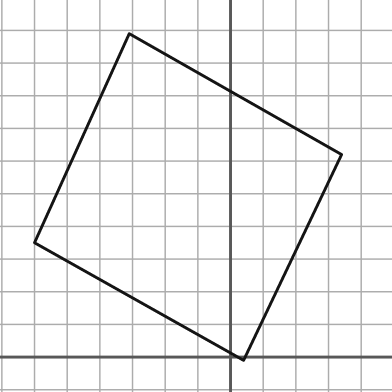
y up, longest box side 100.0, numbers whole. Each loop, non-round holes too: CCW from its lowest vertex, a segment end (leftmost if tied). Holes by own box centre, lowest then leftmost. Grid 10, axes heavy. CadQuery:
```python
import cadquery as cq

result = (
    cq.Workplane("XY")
    .moveTo(4.0, -1.0)
    .lineTo(34.0, 62.0)
    .lineTo(-31.0, 99.0)
    .lineTo(-60.0, 35.0)
    .close()
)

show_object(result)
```